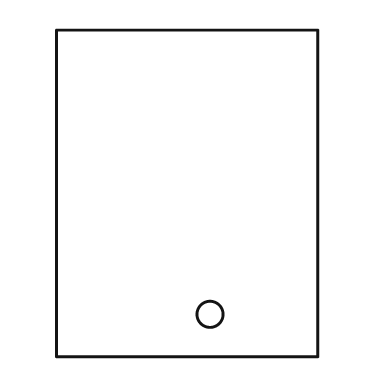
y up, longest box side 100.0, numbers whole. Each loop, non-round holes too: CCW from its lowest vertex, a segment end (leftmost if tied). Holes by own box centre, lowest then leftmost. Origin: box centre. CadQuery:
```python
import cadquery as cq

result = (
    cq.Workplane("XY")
    .moveTo(-40.0, -50.0)
    .lineTo(40.0, -50.0)
    .lineTo(40.0, 50.0)
    .lineTo(-40.0, 50.0)
    .close()
    .moveTo(7.0, -37.0)
    .circle(4.0)
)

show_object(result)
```